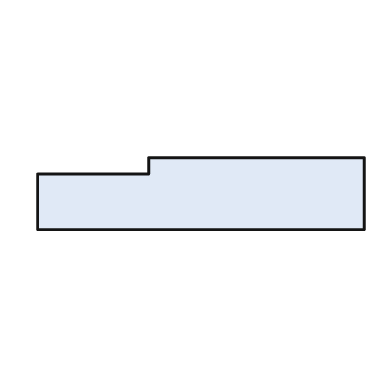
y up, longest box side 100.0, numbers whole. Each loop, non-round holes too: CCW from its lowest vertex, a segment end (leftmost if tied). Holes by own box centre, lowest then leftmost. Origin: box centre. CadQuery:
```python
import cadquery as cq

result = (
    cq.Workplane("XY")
    .moveTo(-50.0, -11.0)
    .lineTo(50.0, -11.0)
    .lineTo(50.0, 11.0)
    .lineTo(-16.0, 11.0)
    .lineTo(-16.0, 6.0)
    .lineTo(-50.0, 6.0)
    .close()
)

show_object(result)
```